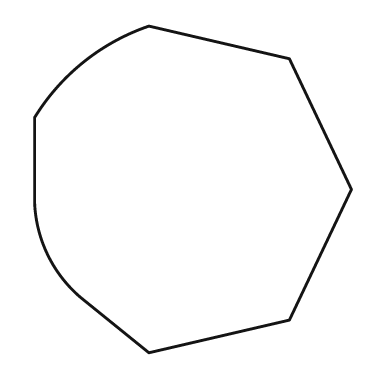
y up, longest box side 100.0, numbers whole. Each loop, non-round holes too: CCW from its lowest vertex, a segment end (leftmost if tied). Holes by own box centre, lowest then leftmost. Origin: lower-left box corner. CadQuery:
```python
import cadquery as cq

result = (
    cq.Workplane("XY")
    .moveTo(35.0, 0.0)
    .lineTo(78.0, 10.0)
    .lineTo(97.0, 50.0)
    .lineTo(78.0, 90.0)
    .lineTo(35.0, 100.0)
    .threePointArc((15.0, 89.0), (0.0, 72.0))
    .lineTo(0.0, 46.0)
    .threePointArc((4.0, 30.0), (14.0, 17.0))
    .close()
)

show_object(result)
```